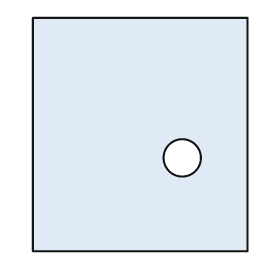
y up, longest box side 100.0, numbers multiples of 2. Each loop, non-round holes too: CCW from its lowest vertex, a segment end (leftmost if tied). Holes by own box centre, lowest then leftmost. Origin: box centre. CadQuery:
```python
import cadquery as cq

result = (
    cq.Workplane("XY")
    .moveTo(-46.0, -50.0)
    .lineTo(46.0, -50.0)
    .lineTo(46.0, 50.0)
    .lineTo(-46.0, 50.0)
    .close()
    .moveTo(18.0, -10.0)
    .circle(8.0)
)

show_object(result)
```